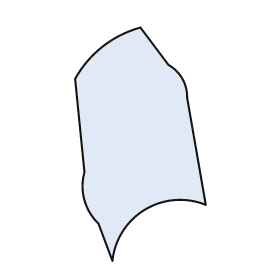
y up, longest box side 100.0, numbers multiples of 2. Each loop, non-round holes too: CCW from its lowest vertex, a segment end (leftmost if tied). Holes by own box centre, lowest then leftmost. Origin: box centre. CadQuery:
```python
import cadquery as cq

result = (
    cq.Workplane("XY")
    .moveTo(-12.0, -50.0)
    .threePointArc((2.0, -28.0), (28.0, -26.0))
    .lineTo(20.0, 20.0)
    .threePointArc((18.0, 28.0), (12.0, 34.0))
    .lineTo(0.0, 50.0)
    .threePointArc((-16.0, 42.0), (-28.0, 28.0))
    .lineTo(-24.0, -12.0)
    .threePointArc((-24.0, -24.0), (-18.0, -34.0))
    .close()
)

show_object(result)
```